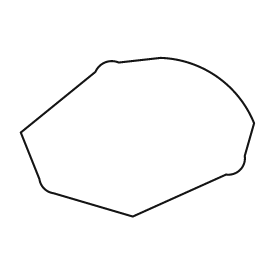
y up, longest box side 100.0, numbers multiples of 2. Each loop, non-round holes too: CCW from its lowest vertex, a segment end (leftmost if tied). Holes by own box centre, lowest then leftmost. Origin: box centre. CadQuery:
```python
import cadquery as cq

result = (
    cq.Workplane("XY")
    .moveTo(-2.0, -34.0)
    .lineTo(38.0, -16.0)
    .threePointArc((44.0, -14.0), (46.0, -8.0))
    .lineTo(50.0, 6.0)
    .threePointArc((34.0, 26.0), (10.0, 34.0))
    .lineTo(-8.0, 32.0)
    .threePointArc((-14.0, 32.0), (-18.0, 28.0))
    .lineTo(-50.0, 2.0)
    .lineTo(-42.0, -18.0)
    .threePointArc((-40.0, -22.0), (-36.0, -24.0))
    .close()
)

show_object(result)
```